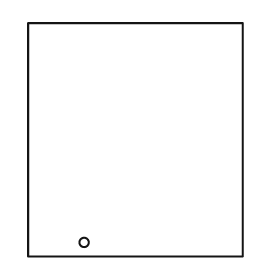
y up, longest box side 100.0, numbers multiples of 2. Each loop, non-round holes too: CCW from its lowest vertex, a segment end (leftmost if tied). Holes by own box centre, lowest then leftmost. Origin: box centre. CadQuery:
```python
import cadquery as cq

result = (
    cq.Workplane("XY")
    .moveTo(-46.0, -50.0)
    .lineTo(46.0, -50.0)
    .lineTo(46.0, 50.0)
    .lineTo(-46.0, 50.0)
    .close()
    .moveTo(-22.0, -44.0)
    .circle(2.0)
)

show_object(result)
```